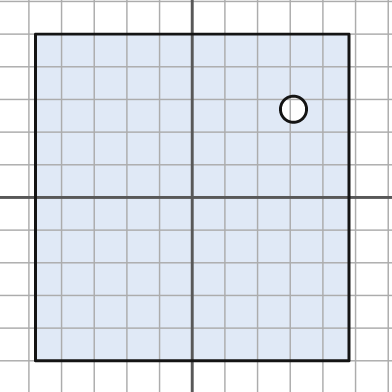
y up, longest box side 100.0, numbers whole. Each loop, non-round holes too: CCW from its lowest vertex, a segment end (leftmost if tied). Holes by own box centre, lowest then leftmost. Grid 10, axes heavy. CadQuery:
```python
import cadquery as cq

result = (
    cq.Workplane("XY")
    .moveTo(-48.0, -50.0)
    .lineTo(48.0, -50.0)
    .lineTo(48.0, 50.0)
    .lineTo(-48.0, 50.0)
    .close()
    .moveTo(31.0, 27.0)
    .circle(4.0)
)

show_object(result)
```